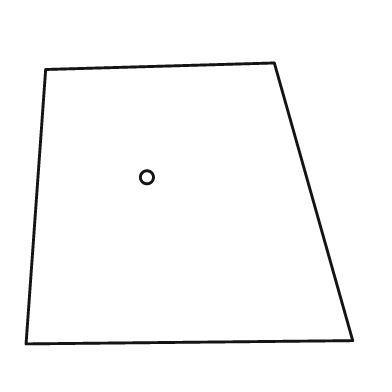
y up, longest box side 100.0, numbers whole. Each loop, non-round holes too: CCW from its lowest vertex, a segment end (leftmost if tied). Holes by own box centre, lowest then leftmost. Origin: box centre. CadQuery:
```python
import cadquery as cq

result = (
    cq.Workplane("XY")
    .moveTo(-50.0, -43.0)
    .lineTo(50.0, -42.0)
    .lineTo(26.0, 43.0)
    .lineTo(-44.0, 41.0)
    .close()
    .moveTo(-13.0, 8.0)
    .circle(2.0)
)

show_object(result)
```